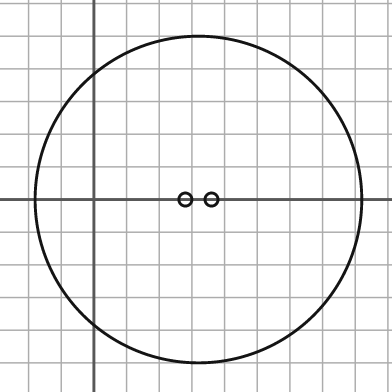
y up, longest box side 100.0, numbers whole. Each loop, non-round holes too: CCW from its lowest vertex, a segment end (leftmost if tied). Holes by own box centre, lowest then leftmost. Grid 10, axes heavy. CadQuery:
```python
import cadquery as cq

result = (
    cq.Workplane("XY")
    .moveTo(32.0, 0.0)
    .circle(50.0)
    .moveTo(28.0, 0.0)
    .circle(2.0)
    .moveTo(36.0, 0.0)
    .circle(2.0)
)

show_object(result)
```